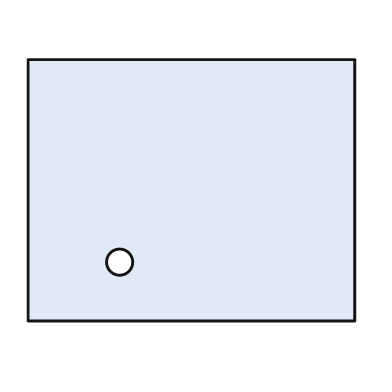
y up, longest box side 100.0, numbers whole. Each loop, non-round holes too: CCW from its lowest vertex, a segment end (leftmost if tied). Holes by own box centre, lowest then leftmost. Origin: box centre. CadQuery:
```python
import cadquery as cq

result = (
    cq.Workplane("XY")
    .moveTo(-50.0, -40.0)
    .lineTo(50.0, -40.0)
    .lineTo(50.0, 40.0)
    .lineTo(-50.0, 40.0)
    .close()
    .moveTo(-22.0, -22.0)
    .circle(4.0)
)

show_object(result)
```